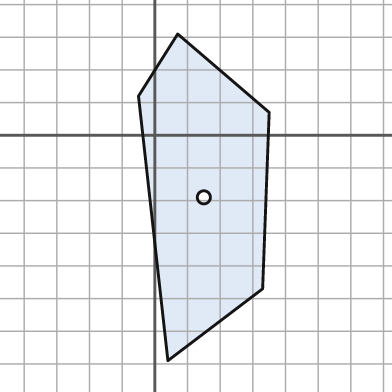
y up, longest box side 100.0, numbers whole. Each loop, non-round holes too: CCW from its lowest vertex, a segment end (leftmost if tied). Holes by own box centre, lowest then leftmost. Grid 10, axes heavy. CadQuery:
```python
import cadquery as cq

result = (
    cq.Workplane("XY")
    .moveTo(4.0, -69.0)
    .lineTo(33.0, -47.0)
    .lineTo(35.0, 7.0)
    .lineTo(7.0, 31.0)
    .lineTo(-5.0, 12.0)
    .close()
    .moveTo(15.0, -19.0)
    .circle(2.0)
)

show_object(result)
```